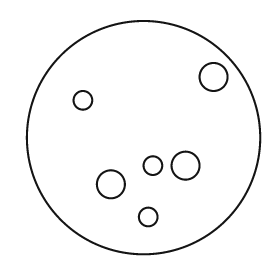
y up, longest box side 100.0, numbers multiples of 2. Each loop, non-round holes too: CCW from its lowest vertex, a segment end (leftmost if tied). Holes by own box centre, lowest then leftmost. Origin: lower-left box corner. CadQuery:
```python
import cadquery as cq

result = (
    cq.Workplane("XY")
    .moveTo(50.0, 50.0)
    .circle(50.0)
    .moveTo(52.0, 16.0)
    .circle(4.0)
    .moveTo(36.0, 30.0)
    .circle(6.0)
    .moveTo(54.0, 38.0)
    .circle(4.0)
    .moveTo(68.0, 38.0)
    .circle(6.0)
    .moveTo(24.0, 66.0)
    .circle(4.0)
    .moveTo(80.0, 76.0)
    .circle(6.0)
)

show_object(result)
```